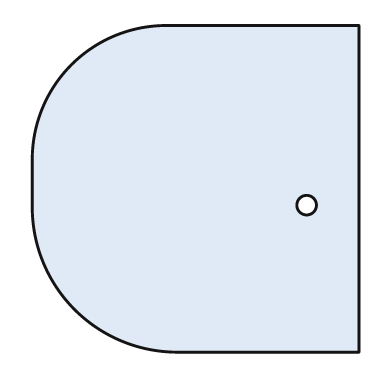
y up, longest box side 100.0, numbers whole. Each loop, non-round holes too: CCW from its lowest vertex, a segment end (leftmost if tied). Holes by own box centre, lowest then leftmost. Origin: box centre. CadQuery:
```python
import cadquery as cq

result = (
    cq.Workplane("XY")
    .moveTo(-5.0, -50.0)
    .lineTo(50.0, -50.0)
    .lineTo(50.0, 50.0)
    .lineTo(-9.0, 50.0)
    .threePointArc((-38.0, 38.0), (-50.0, 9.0))
    .lineTo(-50.0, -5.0)
    .threePointArc((-37.0, -37.0), (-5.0, -50.0))
    .close()
    .moveTo(34.0, -5.0)
    .circle(3.0)
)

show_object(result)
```